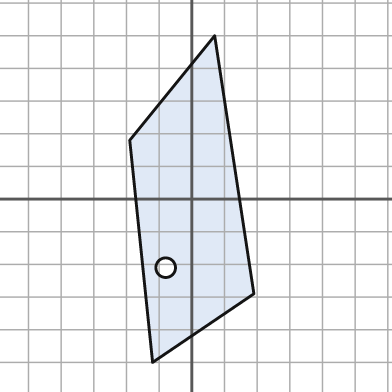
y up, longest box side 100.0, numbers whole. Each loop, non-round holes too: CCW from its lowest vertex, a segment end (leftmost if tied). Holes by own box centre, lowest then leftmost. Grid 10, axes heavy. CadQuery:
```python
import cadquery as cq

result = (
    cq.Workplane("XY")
    .moveTo(-12.0, -50.0)
    .lineTo(19.0, -29.0)
    .lineTo(7.0, 50.0)
    .lineTo(-19.0, 18.0)
    .close()
    .moveTo(-8.0, -21.0)
    .circle(3.0)
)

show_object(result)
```